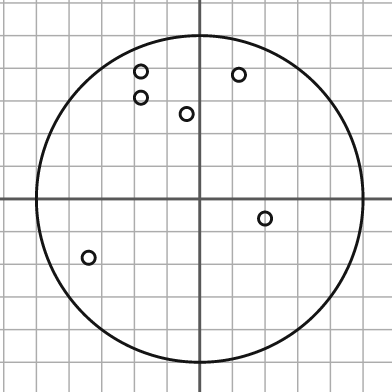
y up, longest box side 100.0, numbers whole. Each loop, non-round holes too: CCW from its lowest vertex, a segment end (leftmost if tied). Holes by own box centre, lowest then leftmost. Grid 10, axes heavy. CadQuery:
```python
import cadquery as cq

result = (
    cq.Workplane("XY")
    .moveTo(0.0, 0.0)
    .circle(50.0)
    .moveTo(-34.0, -18.0)
    .circle(2.0)
    .moveTo(20.0, -6.0)
    .circle(2.0)
    .moveTo(-4.0, 26.0)
    .circle(2.0)
    .moveTo(-18.0, 31.0)
    .circle(2.0)
    .moveTo(12.0, 38.0)
    .circle(2.0)
    .moveTo(-18.0, 39.0)
    .circle(2.0)
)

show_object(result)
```